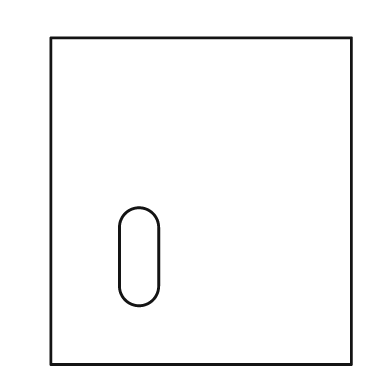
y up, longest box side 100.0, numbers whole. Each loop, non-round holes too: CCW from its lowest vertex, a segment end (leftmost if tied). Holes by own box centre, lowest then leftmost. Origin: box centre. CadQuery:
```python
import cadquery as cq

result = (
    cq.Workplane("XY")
    .moveTo(-46.0, -50.0)
    .lineTo(46.0, -50.0)
    .lineTo(46.0, 50.0)
    .lineTo(-46.0, 50.0)
    .close()
    .moveTo(-25.0, -26.0)
    .threePointArc((-19.0, -32.0), (-13.0, -26.0))
    .lineTo(-13.0, -8.0)
    .threePointArc((-19.0, -2.0), (-25.0, -8.0))
    .close()
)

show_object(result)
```